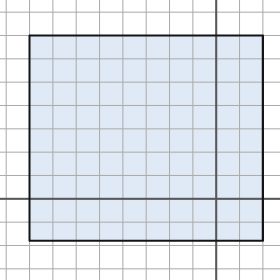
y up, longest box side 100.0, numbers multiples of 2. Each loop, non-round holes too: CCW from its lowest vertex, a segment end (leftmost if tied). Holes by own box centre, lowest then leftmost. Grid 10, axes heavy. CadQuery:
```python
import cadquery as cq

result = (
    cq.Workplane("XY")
    .moveTo(-80.0, -18.0)
    .lineTo(20.0, -18.0)
    .lineTo(20.0, 70.0)
    .lineTo(-80.0, 70.0)
    .close()
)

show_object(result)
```